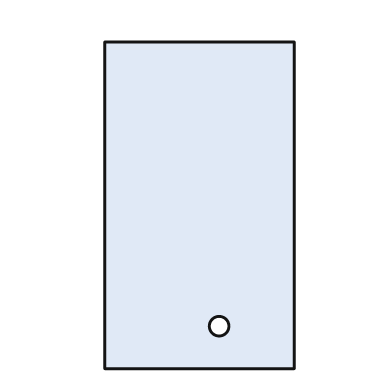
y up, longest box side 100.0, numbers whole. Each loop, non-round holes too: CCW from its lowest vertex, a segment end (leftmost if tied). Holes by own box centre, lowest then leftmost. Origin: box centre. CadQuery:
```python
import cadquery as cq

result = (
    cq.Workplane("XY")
    .moveTo(-29.0, -50.0)
    .lineTo(29.0, -50.0)
    .lineTo(29.0, 50.0)
    .lineTo(-29.0, 50.0)
    .close()
    .moveTo(6.0, -37.0)
    .circle(3.0)
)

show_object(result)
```